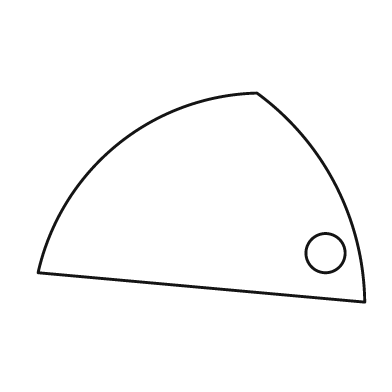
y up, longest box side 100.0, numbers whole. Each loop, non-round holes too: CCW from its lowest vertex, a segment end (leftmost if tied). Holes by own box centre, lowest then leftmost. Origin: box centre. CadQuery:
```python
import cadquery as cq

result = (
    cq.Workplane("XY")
    .moveTo(50.0, -32.0)
    .threePointArc((41.0, 4.0), (17.0, 32.0))
    .threePointArc((-26.0, 16.0), (-50.0, -23.0))
    .close()
    .moveTo(38.0, -17.0)
    .circle(6.0)
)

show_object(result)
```